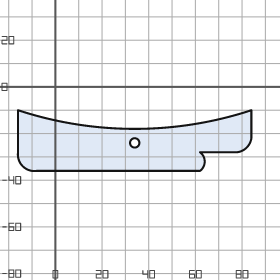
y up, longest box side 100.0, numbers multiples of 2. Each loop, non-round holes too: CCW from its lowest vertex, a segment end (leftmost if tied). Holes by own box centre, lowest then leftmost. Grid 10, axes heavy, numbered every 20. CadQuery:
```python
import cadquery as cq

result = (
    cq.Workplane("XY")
    .moveTo(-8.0, -36.0)
    .lineTo(62.0, -36.0)
    .threePointArc((64.0, -32.0), (62.0, -28.0))
    .lineTo(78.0, -28.0)
    .threePointArc((82.0, -26.0), (84.0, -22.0))
    .lineTo(84.0, -10.0)
    .threePointArc((34.0, -18.0), (-16.0, -10.0))
    .lineTo(-16.0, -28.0)
    .threePointArc((-14.0, -34.0), (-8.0, -36.0))
    .close()
    .moveTo(34.0, -24.0)
    .circle(2.0)
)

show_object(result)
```